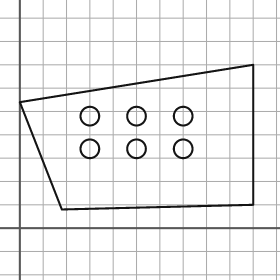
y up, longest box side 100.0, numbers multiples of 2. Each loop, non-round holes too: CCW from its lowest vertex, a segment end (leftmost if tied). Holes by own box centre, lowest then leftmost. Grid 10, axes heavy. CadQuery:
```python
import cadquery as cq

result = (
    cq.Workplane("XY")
    .moveTo(18.0, 8.0)
    .lineTo(100.0, 10.0)
    .lineTo(100.0, 70.0)
    .lineTo(0.0, 54.0)
    .close()
    .moveTo(30.0, 34.0)
    .circle(4.0)
    .moveTo(50.0, 34.0)
    .circle(4.0)
    .moveTo(70.0, 34.0)
    .circle(4.0)
    .moveTo(30.0, 48.0)
    .circle(4.0)
    .moveTo(50.0, 48.0)
    .circle(4.0)
    .moveTo(70.0, 48.0)
    .circle(4.0)
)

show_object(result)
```